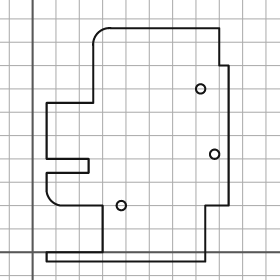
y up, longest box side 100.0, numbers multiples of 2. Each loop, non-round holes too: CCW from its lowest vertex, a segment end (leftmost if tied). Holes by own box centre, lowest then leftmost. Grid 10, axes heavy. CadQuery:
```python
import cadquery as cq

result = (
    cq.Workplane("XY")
    .moveTo(6.0, -4.0)
    .lineTo(74.0, -4.0)
    .lineTo(74.0, 20.0)
    .lineTo(84.0, 20.0)
    .lineTo(84.0, 80.0)
    .lineTo(80.0, 80.0)
    .lineTo(80.0, 96.0)
    .lineTo(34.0, 96.0)
    .threePointArc((28.0, 94.0), (26.0, 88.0))
    .lineTo(26.0, 64.0)
    .lineTo(6.0, 64.0)
    .lineTo(6.0, 40.0)
    .lineTo(24.0, 40.0)
    .lineTo(24.0, 34.0)
    .lineTo(6.0, 34.0)
    .lineTo(6.0, 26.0)
    .threePointArc((8.0, 22.0), (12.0, 20.0))
    .lineTo(30.0, 20.0)
    .lineTo(30.0, 0.0)
    .lineTo(6.0, 0.0)
    .close()
    .moveTo(38.0, 20.0)
    .circle(2.0)
    .moveTo(78.0, 42.0)
    .circle(2.0)
    .moveTo(72.0, 70.0)
    .circle(2.0)
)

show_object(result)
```